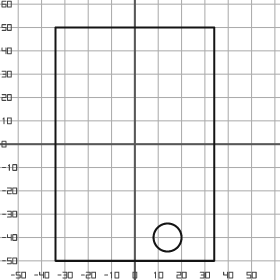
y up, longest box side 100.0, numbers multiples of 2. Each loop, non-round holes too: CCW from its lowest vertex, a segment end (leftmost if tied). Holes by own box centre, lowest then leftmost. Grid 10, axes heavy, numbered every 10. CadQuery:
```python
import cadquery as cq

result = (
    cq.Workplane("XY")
    .moveTo(-34.0, -50.0)
    .lineTo(34.0, -50.0)
    .lineTo(34.0, 50.0)
    .lineTo(-34.0, 50.0)
    .close()
    .moveTo(14.0, -40.0)
    .circle(6.0)
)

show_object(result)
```